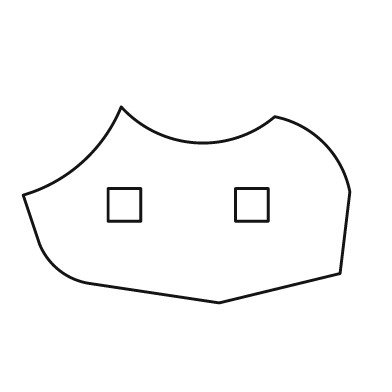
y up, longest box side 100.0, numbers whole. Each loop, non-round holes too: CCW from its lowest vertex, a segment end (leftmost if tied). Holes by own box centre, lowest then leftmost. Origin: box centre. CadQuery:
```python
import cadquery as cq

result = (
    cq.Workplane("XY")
    .moveTo(10.0, -30.0)
    .lineTo(47.0, -21.0)
    .lineTo(50.0, 4.0)
    .threePointArc((42.0, 19.0), (27.0, 27.0))
    .threePointArc((3.0, 19.0), (-20.0, 30.0))
    .threePointArc((-32.0, 13.0), (-50.0, 3.0))
    .lineTo(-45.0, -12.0)
    .threePointArc((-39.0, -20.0), (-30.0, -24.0))
    .close()
    .moveTo(-24.0, -5.0)
    .lineTo(-14.0, -5.0)
    .lineTo(-14.0, 5.0)
    .lineTo(-24.0, 5.0)
    .close()
    .moveTo(15.0, -5.0)
    .lineTo(25.0, -5.0)
    .lineTo(25.0, 5.0)
    .lineTo(15.0, 5.0)
    .close()
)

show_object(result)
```